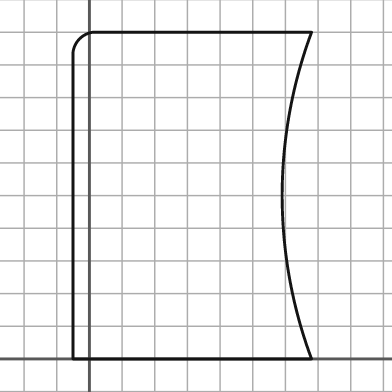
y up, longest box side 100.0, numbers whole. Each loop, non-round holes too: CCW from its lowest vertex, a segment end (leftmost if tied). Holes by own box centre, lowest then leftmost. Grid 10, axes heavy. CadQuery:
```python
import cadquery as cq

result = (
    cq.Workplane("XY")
    .moveTo(-5.0, 0.0)
    .lineTo(68.0, 0.0)
    .threePointArc((59.0, 50.0), (68.0, 100.0))
    .lineTo(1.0, 100.0)
    .threePointArc((-3.0, 98.0), (-5.0, 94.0))
    .close()
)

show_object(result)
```